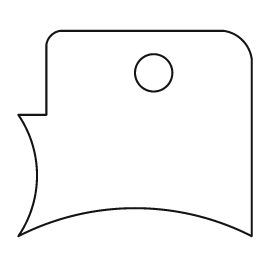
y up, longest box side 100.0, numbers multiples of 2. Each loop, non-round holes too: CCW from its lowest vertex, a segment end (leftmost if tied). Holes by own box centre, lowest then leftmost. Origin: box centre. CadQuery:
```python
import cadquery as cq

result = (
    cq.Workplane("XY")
    .moveTo(-50.0, -44.0)
    .threePointArc((0.0, -32.0), (50.0, -44.0))
    .lineTo(50.0, 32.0)
    .threePointArc((46.0, 40.0), (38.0, 44.0))
    .lineTo(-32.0, 44.0)
    .threePointArc((-36.0, 42.0), (-38.0, 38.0))
    .lineTo(-38.0, 8.0)
    .lineTo(-50.0, 8.0)
    .threePointArc((-42.0, -18.0), (-50.0, -44.0))
    .close()
    .moveTo(8.0, 26.0)
    .circle(8.0)
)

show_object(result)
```